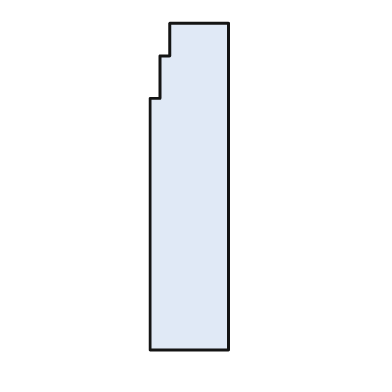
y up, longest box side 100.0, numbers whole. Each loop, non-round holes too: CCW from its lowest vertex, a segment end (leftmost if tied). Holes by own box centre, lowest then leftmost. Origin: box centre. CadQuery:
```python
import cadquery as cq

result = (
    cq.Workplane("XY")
    .moveTo(-12.0, -50.0)
    .lineTo(12.0, -50.0)
    .lineTo(12.0, 50.0)
    .lineTo(-6.0, 50.0)
    .lineTo(-6.0, 40.0)
    .lineTo(-9.0, 40.0)
    .lineTo(-9.0, 27.0)
    .lineTo(-12.0, 27.0)
    .close()
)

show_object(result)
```